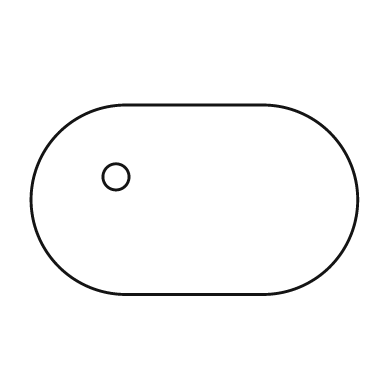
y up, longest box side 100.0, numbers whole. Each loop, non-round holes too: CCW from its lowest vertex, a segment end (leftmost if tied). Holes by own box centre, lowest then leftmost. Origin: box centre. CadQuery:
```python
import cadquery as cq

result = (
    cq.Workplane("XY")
    .moveTo(-21.0, -29.0)
    .lineTo(21.0, -29.0)
    .threePointArc((50.0, 0.0), (21.0, 29.0))
    .lineTo(-21.0, 29.0)
    .threePointArc((-50.0, 0.0), (-21.0, -29.0))
    .close()
    .moveTo(-24.0, 7.0)
    .circle(4.0)
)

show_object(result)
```